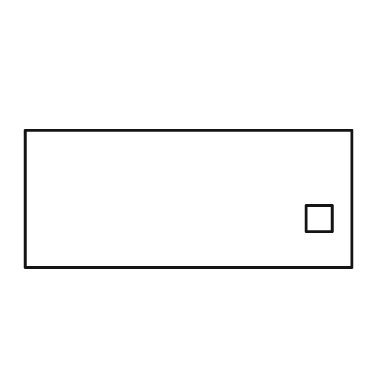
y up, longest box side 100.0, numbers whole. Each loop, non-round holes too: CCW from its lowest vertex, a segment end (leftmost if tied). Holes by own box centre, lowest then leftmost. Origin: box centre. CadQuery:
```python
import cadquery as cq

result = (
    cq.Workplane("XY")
    .moveTo(-50.0, -21.0)
    .lineTo(50.0, -21.0)
    .lineTo(50.0, 21.0)
    .lineTo(-50.0, 21.0)
    .close()
    .moveTo(36.0, -10.0)
    .lineTo(44.0, -10.0)
    .lineTo(44.0, -2.0)
    .lineTo(36.0, -2.0)
    .close()
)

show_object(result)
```